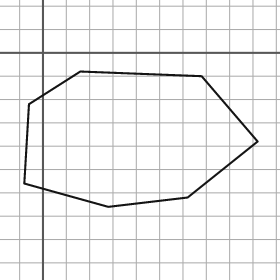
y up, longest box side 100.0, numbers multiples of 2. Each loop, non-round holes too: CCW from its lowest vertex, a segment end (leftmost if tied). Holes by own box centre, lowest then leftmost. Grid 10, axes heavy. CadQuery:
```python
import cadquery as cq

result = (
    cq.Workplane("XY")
    .moveTo(28.0, -66.0)
    .lineTo(62.0, -62.0)
    .lineTo(92.0, -38.0)
    .lineTo(68.0, -10.0)
    .lineTo(16.0, -8.0)
    .lineTo(-6.0, -22.0)
    .lineTo(-8.0, -56.0)
    .close()
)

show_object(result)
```